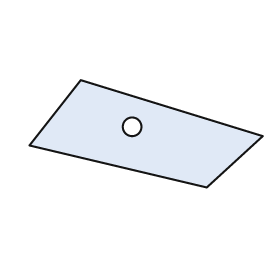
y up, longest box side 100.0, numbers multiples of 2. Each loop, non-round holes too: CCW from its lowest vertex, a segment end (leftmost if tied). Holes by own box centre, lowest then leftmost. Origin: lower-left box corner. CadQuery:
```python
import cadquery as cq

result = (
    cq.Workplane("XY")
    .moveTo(76.0, 0.0)
    .lineTo(100.0, 22.0)
    .lineTo(22.0, 46.0)
    .lineTo(0.0, 18.0)
    .close()
    .moveTo(44.0, 26.0)
    .circle(4.0)
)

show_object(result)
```